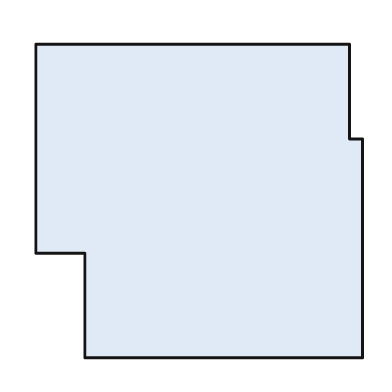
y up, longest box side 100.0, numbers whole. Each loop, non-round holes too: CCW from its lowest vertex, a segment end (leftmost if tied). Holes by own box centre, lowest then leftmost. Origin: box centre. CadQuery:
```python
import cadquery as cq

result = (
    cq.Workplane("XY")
    .moveTo(-35.0, -48.0)
    .lineTo(50.0, -48.0)
    .lineTo(50.0, 19.0)
    .lineTo(46.0, 19.0)
    .lineTo(46.0, 48.0)
    .lineTo(-50.0, 48.0)
    .lineTo(-50.0, -16.0)
    .lineTo(-35.0, -16.0)
    .close()
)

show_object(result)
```